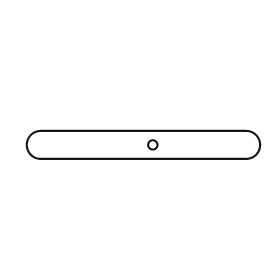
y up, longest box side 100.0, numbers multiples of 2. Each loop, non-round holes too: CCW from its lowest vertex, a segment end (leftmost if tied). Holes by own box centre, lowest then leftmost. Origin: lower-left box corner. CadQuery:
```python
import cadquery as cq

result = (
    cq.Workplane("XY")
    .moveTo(6.0, 0.0)
    .lineTo(94.0, 0.0)
    .threePointArc((100.0, 6.0), (94.0, 12.0))
    .lineTo(6.0, 12.0)
    .threePointArc((0.0, 6.0), (6.0, 0.0))
    .close()
    .moveTo(54.0, 6.0)
    .circle(2.0)
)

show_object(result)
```